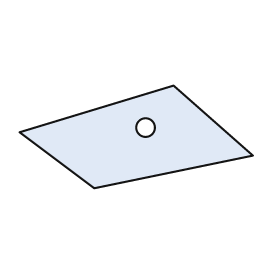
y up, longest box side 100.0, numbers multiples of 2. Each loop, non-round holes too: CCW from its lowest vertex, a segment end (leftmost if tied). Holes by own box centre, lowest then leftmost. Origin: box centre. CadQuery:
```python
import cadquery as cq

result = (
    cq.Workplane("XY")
    .moveTo(-18.0, -22.0)
    .lineTo(50.0, -8.0)
    .lineTo(16.0, 22.0)
    .lineTo(-50.0, 2.0)
    .close()
    .moveTo(4.0, 4.0)
    .circle(4.0)
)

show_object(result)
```